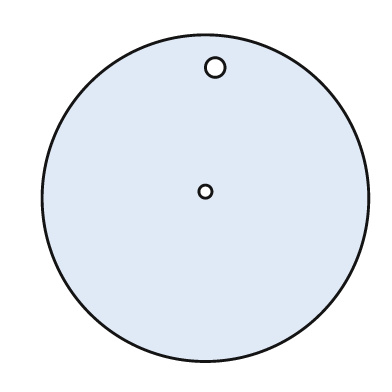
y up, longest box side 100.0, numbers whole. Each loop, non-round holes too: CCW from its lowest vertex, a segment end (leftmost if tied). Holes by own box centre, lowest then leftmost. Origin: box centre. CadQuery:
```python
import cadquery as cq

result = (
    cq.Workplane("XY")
    .moveTo(0.0, 0.0)
    .circle(50.0)
    .moveTo(0.0, 2.0)
    .circle(2.0)
    .moveTo(3.0, 40.0)
    .circle(3.0)
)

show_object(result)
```